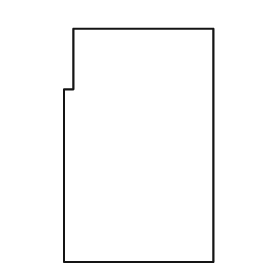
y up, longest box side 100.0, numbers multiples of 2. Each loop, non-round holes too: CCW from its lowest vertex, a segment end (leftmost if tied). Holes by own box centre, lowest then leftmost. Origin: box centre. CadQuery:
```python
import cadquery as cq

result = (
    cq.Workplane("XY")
    .moveTo(-32.0, -50.0)
    .lineTo(32.0, -50.0)
    .lineTo(32.0, 50.0)
    .lineTo(-28.0, 50.0)
    .lineTo(-28.0, 24.0)
    .lineTo(-32.0, 24.0)
    .close()
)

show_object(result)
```